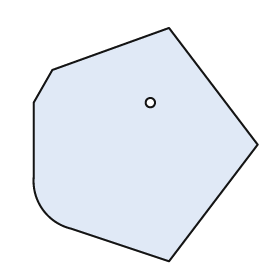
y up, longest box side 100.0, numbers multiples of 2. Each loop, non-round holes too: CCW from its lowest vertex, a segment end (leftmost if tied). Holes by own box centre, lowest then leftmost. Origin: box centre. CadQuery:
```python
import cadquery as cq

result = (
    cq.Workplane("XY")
    .moveTo(10.0, -50.0)
    .lineTo(48.0, 0.0)
    .lineTo(10.0, 50.0)
    .lineTo(-40.0, 32.0)
    .lineTo(-48.0, 18.0)
    .lineTo(-48.0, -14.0)
    .threePointArc((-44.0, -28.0), (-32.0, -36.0))
    .close()
    .moveTo(2.0, 18.0)
    .circle(2.0)
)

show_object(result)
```